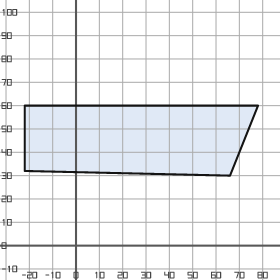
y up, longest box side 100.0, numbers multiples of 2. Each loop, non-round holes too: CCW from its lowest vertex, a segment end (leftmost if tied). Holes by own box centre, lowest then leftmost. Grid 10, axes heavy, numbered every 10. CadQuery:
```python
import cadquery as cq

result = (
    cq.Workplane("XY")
    .moveTo(66.0, 30.0)
    .lineTo(78.0, 60.0)
    .lineTo(-22.0, 60.0)
    .lineTo(-22.0, 32.0)
    .close()
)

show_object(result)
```